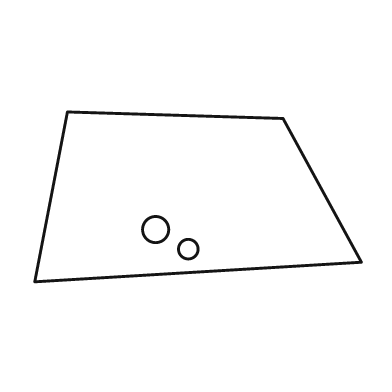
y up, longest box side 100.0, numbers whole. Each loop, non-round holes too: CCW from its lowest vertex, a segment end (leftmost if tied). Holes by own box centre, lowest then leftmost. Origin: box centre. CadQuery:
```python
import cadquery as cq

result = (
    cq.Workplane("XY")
    .moveTo(-50.0, -26.0)
    .lineTo(50.0, -20.0)
    .lineTo(26.0, 24.0)
    .lineTo(-40.0, 26.0)
    .close()
    .moveTo(-3.0, -16.0)
    .circle(3.0)
    .moveTo(-13.0, -10.0)
    .circle(4.0)
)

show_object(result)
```